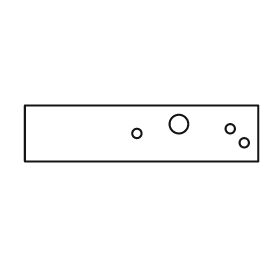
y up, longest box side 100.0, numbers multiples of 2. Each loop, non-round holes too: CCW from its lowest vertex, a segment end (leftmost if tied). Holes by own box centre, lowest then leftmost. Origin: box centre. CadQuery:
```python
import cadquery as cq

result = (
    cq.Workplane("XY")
    .moveTo(-50.0, -12.0)
    .lineTo(50.0, -12.0)
    .lineTo(50.0, 12.0)
    .lineTo(-50.0, 12.0)
    .close()
    .moveTo(44.0, -4.0)
    .circle(2.0)
    .moveTo(-2.0, 0.0)
    .circle(2.0)
    .moveTo(38.0, 2.0)
    .circle(2.0)
    .moveTo(16.0, 4.0)
    .circle(4.0)
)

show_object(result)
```